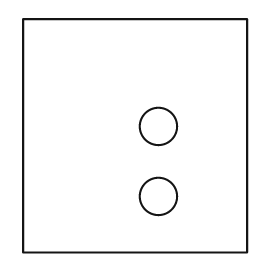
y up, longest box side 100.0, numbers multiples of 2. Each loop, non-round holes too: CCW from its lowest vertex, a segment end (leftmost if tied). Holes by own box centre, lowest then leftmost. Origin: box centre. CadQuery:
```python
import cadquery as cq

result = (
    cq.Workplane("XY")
    .moveTo(-48.0, -50.0)
    .lineTo(48.0, -50.0)
    .lineTo(48.0, 50.0)
    .lineTo(-48.0, 50.0)
    .close()
    .moveTo(10.0, -26.0)
    .circle(8.0)
    .moveTo(10.0, 4.0)
    .circle(8.0)
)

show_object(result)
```